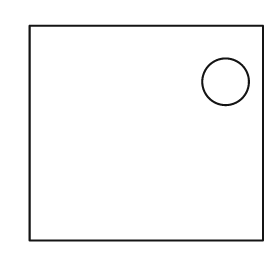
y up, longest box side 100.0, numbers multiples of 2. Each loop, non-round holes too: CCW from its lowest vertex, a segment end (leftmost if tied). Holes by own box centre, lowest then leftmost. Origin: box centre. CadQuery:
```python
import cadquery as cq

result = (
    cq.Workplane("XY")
    .moveTo(-50.0, -46.0)
    .lineTo(50.0, -46.0)
    .lineTo(50.0, 46.0)
    .lineTo(-50.0, 46.0)
    .close()
    .moveTo(34.0, 22.0)
    .circle(10.0)
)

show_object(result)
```